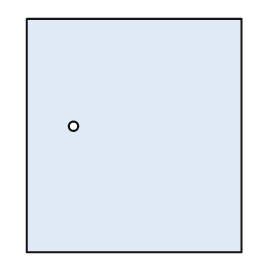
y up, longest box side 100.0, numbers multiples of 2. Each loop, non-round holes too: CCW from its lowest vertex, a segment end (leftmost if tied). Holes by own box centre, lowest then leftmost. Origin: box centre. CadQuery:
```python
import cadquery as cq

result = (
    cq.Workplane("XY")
    .moveTo(-46.0, -50.0)
    .lineTo(46.0, -50.0)
    .lineTo(46.0, 50.0)
    .lineTo(-46.0, 50.0)
    .close()
    .moveTo(-26.0, 4.0)
    .circle(2.0)
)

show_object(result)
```